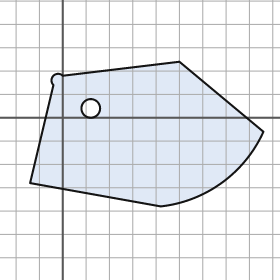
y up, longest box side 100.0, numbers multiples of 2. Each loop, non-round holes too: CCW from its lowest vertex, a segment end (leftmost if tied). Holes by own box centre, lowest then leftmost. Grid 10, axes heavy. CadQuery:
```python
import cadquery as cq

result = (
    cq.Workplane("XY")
    .moveTo(42.0, -38.0)
    .threePointArc((68.0, -28.0), (86.0, -6.0))
    .lineTo(50.0, 24.0)
    .lineTo(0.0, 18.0)
    .threePointArc((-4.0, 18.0), (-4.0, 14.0))
    .lineTo(-14.0, -28.0)
    .close()
    .moveTo(12.0, 4.0)
    .circle(4.0)
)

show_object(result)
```